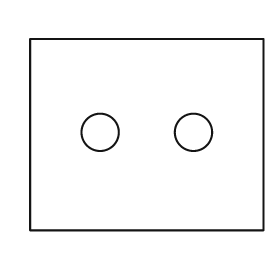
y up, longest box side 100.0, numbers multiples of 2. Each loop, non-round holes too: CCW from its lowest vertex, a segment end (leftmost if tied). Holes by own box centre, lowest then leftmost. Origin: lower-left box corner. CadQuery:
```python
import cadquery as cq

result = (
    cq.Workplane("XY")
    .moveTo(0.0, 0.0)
    .lineTo(100.0, 0.0)
    .lineTo(100.0, 82.0)
    .lineTo(0.0, 82.0)
    .close()
    .moveTo(30.0, 42.0)
    .circle(8.0)
    .moveTo(70.0, 42.0)
    .circle(8.0)
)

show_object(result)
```